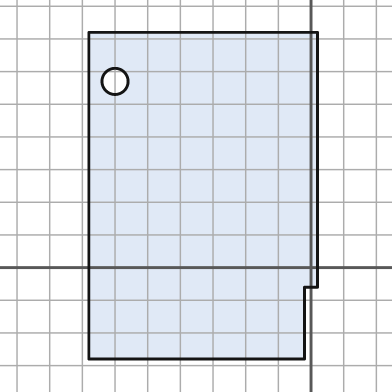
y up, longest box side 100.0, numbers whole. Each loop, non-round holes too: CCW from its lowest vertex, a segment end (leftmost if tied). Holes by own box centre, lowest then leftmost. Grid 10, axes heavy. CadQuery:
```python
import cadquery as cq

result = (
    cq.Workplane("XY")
    .moveTo(-68.0, -28.0)
    .lineTo(-2.0, -28.0)
    .lineTo(-2.0, -6.0)
    .lineTo(2.0, -6.0)
    .lineTo(2.0, 72.0)
    .lineTo(-68.0, 72.0)
    .close()
    .moveTo(-60.0, 57.0)
    .circle(4.0)
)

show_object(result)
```